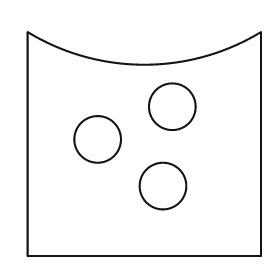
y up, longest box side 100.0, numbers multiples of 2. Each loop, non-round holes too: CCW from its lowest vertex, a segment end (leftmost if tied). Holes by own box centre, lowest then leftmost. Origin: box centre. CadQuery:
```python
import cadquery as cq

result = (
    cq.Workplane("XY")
    .moveTo(-50.0, -48.0)
    .lineTo(50.0, -48.0)
    .lineTo(50.0, 48.0)
    .threePointArc((0.0, 34.0), (-50.0, 48.0))
    .close()
    .moveTo(8.0, -18.0)
    .circle(10.0)
    .moveTo(-20.0, 2.0)
    .circle(10.0)
    .moveTo(12.0, 16.0)
    .circle(10.0)
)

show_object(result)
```